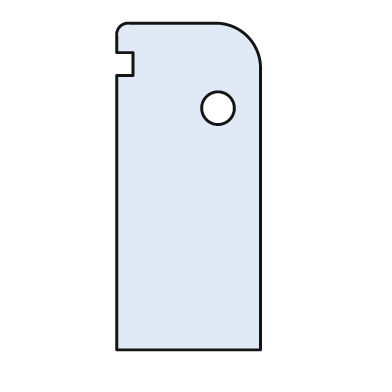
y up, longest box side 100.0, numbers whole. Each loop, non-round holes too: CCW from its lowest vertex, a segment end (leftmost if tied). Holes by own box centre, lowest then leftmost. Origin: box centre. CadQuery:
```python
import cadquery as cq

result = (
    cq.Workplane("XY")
    .moveTo(-22.0, -50.0)
    .lineTo(22.0, -50.0)
    .lineTo(22.0, 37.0)
    .threePointArc((18.0, 46.0), (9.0, 50.0))
    .lineTo(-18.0, 50.0)
    .threePointArc((-21.0, 49.0), (-22.0, 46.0))
    .lineTo(-22.0, 41.0)
    .lineTo(-17.0, 41.0)
    .lineTo(-17.0, 34.0)
    .lineTo(-22.0, 34.0)
    .close()
    .moveTo(9.0, 24.0)
    .circle(5.0)
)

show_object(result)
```